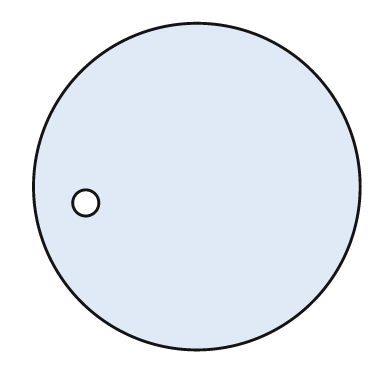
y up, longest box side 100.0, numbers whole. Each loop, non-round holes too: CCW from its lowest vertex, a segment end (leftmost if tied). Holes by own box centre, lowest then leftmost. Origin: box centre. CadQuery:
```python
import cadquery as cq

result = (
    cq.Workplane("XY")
    .moveTo(0.0, 0.0)
    .circle(50.0)
    .moveTo(-34.0, -5.0)
    .circle(4.0)
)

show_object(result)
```